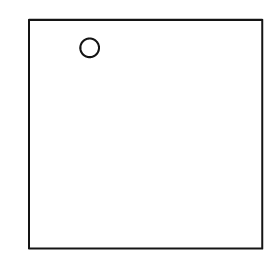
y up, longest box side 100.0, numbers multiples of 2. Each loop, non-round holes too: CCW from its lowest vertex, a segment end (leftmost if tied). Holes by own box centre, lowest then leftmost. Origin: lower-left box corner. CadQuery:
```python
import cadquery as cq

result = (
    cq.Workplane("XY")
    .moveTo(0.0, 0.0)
    .lineTo(100.0, 0.0)
    .lineTo(100.0, 98.0)
    .lineTo(0.0, 98.0)
    .close()
    .moveTo(26.0, 86.0)
    .circle(4.0)
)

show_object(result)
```